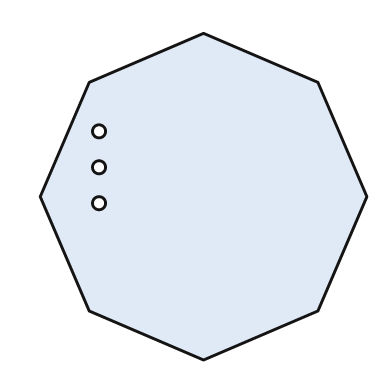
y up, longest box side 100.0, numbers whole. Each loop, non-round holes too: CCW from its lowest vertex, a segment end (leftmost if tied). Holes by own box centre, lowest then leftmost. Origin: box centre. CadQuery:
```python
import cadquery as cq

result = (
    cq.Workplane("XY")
    .moveTo(0.0, -50.0)
    .lineTo(35.0, -35.0)
    .lineTo(50.0, 0.0)
    .lineTo(35.0, 35.0)
    .lineTo(0.0, 50.0)
    .lineTo(-35.0, 35.0)
    .lineTo(-50.0, 0.0)
    .lineTo(-35.0, -35.0)
    .close()
    .moveTo(-32.0, -2.0)
    .circle(2.0)
    .moveTo(-32.0, 9.0)
    .circle(2.0)
    .moveTo(-32.0, 20.0)
    .circle(2.0)
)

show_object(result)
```